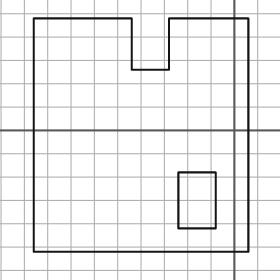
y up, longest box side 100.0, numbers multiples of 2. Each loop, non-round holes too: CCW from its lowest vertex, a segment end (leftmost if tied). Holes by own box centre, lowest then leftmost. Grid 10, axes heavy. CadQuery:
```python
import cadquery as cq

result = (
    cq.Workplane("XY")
    .moveTo(-86.0, -52.0)
    .lineTo(6.0, -52.0)
    .lineTo(6.0, 48.0)
    .lineTo(-28.0, 48.0)
    .lineTo(-28.0, 26.0)
    .lineTo(-44.0, 26.0)
    .lineTo(-44.0, 48.0)
    .lineTo(-86.0, 48.0)
    .close()
    .moveTo(-24.0, -42.0)
    .lineTo(-8.0, -42.0)
    .lineTo(-8.0, -18.0)
    .lineTo(-24.0, -18.0)
    .close()
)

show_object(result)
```